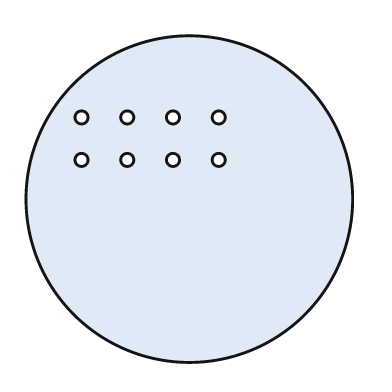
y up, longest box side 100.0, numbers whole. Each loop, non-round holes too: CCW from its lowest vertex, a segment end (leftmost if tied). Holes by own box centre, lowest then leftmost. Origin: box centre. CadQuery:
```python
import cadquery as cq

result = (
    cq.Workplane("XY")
    .moveTo(0.0, 0.0)
    .circle(50.0)
    .moveTo(-33.0, 12.0)
    .circle(2.0)
    .moveTo(-19.0, 12.0)
    .circle(2.0)
    .moveTo(-5.0, 12.0)
    .circle(2.0)
    .moveTo(9.0, 12.0)
    .circle(2.0)
    .moveTo(-33.0, 25.0)
    .circle(2.0)
    .moveTo(-19.0, 25.0)
    .circle(2.0)
    .moveTo(-5.0, 25.0)
    .circle(2.0)
    .moveTo(9.0, 25.0)
    .circle(2.0)
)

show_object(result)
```